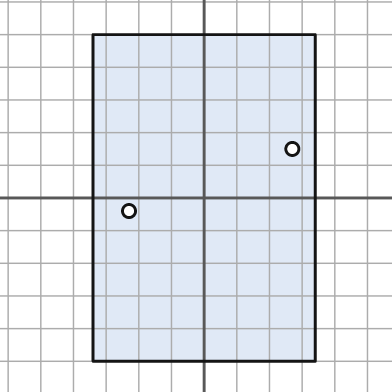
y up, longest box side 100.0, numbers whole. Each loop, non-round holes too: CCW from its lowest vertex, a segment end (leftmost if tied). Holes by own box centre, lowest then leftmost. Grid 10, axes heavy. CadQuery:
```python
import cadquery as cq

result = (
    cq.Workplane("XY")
    .moveTo(-34.0, -50.0)
    .lineTo(34.0, -50.0)
    .lineTo(34.0, 50.0)
    .lineTo(-34.0, 50.0)
    .close()
    .moveTo(-23.0, -4.0)
    .circle(2.0)
    .moveTo(27.0, 15.0)
    .circle(2.0)
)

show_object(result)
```